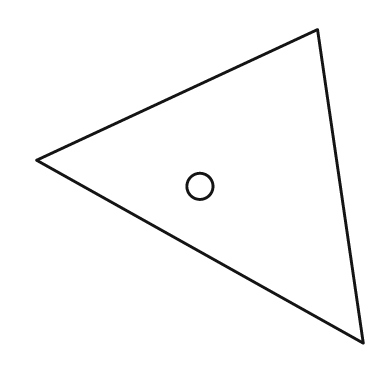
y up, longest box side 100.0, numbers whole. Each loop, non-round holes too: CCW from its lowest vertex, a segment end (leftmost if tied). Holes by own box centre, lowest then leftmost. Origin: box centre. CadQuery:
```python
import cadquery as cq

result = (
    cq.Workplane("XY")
    .moveTo(50.0, -48.0)
    .lineTo(36.0, 48.0)
    .lineTo(-50.0, 8.0)
    .close()
    .moveTo(0.0, 0.0)
    .circle(4.0)
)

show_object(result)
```